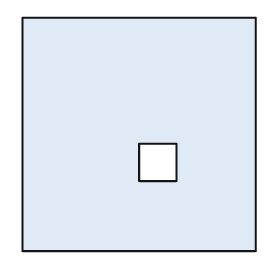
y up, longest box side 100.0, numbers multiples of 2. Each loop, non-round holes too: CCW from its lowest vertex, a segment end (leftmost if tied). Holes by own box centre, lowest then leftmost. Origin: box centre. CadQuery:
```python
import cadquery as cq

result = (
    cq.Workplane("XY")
    .moveTo(-50.0, -50.0)
    .lineTo(50.0, -50.0)
    .lineTo(50.0, 50.0)
    .lineTo(-50.0, 50.0)
    .close()
    .moveTo(0.0, -20.0)
    .lineTo(16.0, -20.0)
    .lineTo(16.0, -4.0)
    .lineTo(0.0, -4.0)
    .close()
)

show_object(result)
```